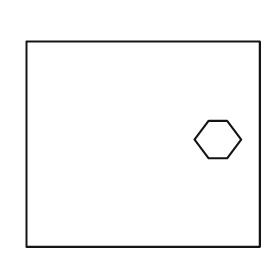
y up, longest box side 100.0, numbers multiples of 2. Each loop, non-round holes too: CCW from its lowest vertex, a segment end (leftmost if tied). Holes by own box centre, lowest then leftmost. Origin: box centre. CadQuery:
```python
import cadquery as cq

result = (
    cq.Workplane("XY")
    .moveTo(-50.0, -44.0)
    .lineTo(50.0, -44.0)
    .lineTo(50.0, 44.0)
    .lineTo(-50.0, 44.0)
    .close()
    .moveTo(28.0, -6.0)
    .lineTo(36.0, -6.0)
    .lineTo(42.0, 2.0)
    .lineTo(36.0, 10.0)
    .lineTo(28.0, 10.0)
    .lineTo(22.0, 2.0)
    .close()
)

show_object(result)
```